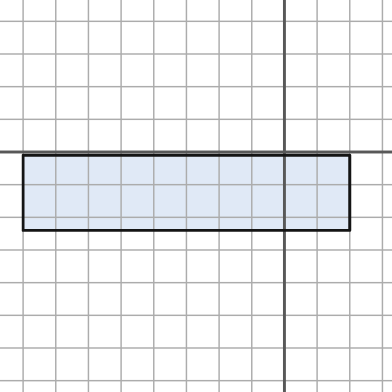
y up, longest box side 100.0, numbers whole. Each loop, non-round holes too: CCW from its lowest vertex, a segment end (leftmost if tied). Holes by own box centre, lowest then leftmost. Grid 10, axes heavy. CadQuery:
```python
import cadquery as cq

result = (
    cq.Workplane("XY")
    .moveTo(-80.0, -24.0)
    .lineTo(20.0, -24.0)
    .lineTo(20.0, -1.0)
    .lineTo(-80.0, -1.0)
    .close()
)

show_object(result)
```